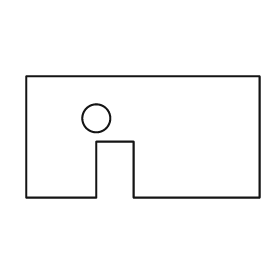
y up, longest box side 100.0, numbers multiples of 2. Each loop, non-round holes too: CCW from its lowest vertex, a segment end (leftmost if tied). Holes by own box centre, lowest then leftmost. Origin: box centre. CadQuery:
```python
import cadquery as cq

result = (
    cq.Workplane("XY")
    .moveTo(-50.0, -26.0)
    .lineTo(-20.0, -26.0)
    .lineTo(-20.0, -2.0)
    .lineTo(-4.0, -2.0)
    .lineTo(-4.0, -26.0)
    .lineTo(50.0, -26.0)
    .lineTo(50.0, 26.0)
    .lineTo(-50.0, 26.0)
    .close()
    .moveTo(-20.0, 8.0)
    .circle(6.0)
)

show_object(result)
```